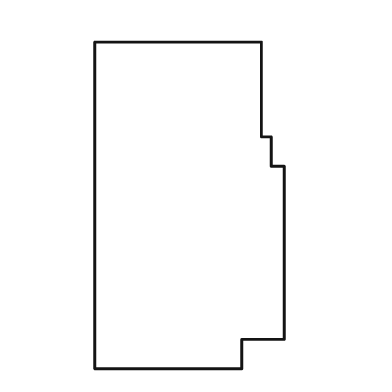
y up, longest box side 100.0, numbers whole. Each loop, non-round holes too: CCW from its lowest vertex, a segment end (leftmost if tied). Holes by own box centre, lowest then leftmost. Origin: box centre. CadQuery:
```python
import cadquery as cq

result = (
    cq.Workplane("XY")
    .moveTo(-29.0, -50.0)
    .lineTo(16.0, -50.0)
    .lineTo(16.0, -41.0)
    .lineTo(29.0, -41.0)
    .lineTo(29.0, 12.0)
    .lineTo(25.0, 12.0)
    .lineTo(25.0, 21.0)
    .lineTo(22.0, 21.0)
    .lineTo(22.0, 50.0)
    .lineTo(-29.0, 50.0)
    .close()
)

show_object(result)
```